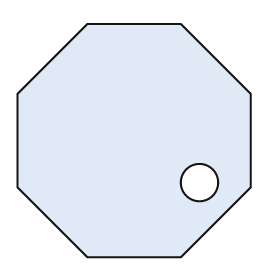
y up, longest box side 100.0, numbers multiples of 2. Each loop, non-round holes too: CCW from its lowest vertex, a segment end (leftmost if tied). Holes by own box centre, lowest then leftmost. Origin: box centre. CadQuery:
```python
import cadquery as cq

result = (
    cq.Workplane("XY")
    .moveTo(-20.0, -50.0)
    .lineTo(20.0, -50.0)
    .lineTo(50.0, -20.0)
    .lineTo(50.0, 20.0)
    .lineTo(20.0, 50.0)
    .lineTo(-20.0, 50.0)
    .lineTo(-50.0, 20.0)
    .lineTo(-50.0, -20.0)
    .close()
    .moveTo(28.0, -18.0)
    .circle(8.0)
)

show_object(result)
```